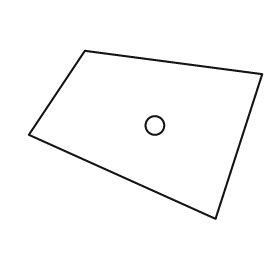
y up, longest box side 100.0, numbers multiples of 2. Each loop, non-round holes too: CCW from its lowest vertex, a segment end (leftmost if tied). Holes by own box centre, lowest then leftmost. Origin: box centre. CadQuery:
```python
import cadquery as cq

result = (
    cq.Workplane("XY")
    .moveTo(30.0, -36.0)
    .lineTo(50.0, 26.0)
    .lineTo(-26.0, 36.0)
    .lineTo(-50.0, 0.0)
    .close()
    .moveTo(4.0, 4.0)
    .circle(4.0)
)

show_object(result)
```